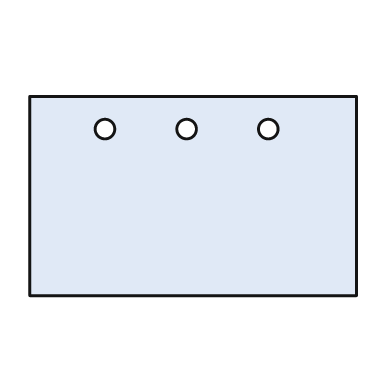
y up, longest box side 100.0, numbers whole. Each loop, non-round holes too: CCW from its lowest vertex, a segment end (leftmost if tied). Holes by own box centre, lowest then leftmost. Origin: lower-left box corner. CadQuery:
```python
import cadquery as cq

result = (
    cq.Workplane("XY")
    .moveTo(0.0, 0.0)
    .lineTo(100.0, 0.0)
    .lineTo(100.0, 61.0)
    .lineTo(0.0, 61.0)
    .close()
    .moveTo(23.0, 51.0)
    .circle(3.0)
    .moveTo(48.0, 51.0)
    .circle(3.0)
    .moveTo(73.0, 51.0)
    .circle(3.0)
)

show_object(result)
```